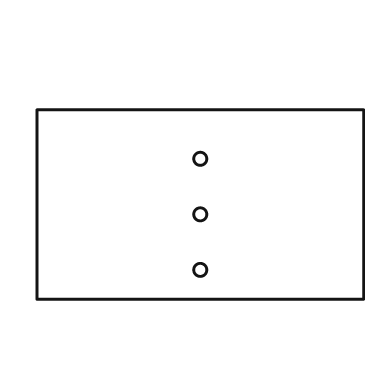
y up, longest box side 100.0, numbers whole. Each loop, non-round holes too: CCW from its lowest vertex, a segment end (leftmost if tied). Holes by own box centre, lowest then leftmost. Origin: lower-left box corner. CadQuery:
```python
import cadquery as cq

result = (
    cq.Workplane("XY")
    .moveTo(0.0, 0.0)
    .lineTo(100.0, 0.0)
    .lineTo(100.0, 58.0)
    .lineTo(0.0, 58.0)
    .close()
    .moveTo(50.0, 9.0)
    .circle(2.0)
    .moveTo(50.0, 26.0)
    .circle(2.0)
    .moveTo(50.0, 43.0)
    .circle(2.0)
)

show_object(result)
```